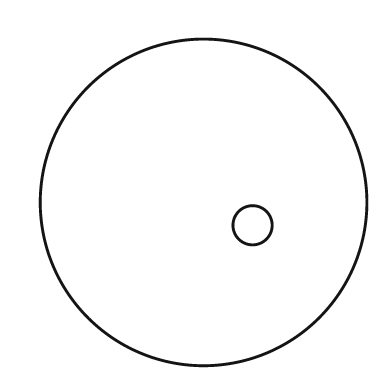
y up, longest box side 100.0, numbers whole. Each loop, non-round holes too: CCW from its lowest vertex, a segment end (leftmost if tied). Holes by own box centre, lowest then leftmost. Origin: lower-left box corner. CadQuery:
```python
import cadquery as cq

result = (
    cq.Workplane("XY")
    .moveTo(50.0, 50.0)
    .circle(50.0)
    .moveTo(65.0, 43.0)
    .circle(6.0)
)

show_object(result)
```